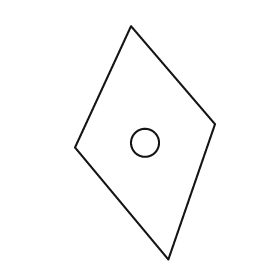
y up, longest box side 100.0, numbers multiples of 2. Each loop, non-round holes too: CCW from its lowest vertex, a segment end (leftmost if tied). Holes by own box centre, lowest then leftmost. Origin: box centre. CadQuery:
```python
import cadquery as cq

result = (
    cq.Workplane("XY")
    .moveTo(10.0, -50.0)
    .lineTo(30.0, 8.0)
    .lineTo(-6.0, 50.0)
    .lineTo(-30.0, -2.0)
    .close()
    .moveTo(0.0, 0.0)
    .circle(6.0)
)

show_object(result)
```